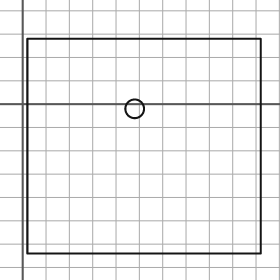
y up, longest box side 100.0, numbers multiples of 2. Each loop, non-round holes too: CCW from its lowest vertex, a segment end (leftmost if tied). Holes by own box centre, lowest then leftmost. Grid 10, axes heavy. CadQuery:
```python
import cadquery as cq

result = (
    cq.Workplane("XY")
    .moveTo(2.0, -64.0)
    .lineTo(102.0, -64.0)
    .lineTo(102.0, 28.0)
    .lineTo(2.0, 28.0)
    .close()
    .moveTo(48.0, -2.0)
    .circle(4.0)
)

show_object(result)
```